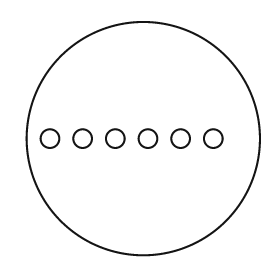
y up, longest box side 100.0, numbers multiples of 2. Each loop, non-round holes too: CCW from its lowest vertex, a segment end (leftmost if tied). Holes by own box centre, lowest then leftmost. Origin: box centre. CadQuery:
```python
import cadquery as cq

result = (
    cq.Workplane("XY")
    .moveTo(0.0, 0.0)
    .circle(50.0)
    .moveTo(-40.0, 0.0)
    .circle(4.0)
    .moveTo(-26.0, 0.0)
    .circle(4.0)
    .moveTo(-12.0, 0.0)
    .circle(4.0)
    .moveTo(2.0, 0.0)
    .circle(4.0)
    .moveTo(16.0, 0.0)
    .circle(4.0)
    .moveTo(30.0, 0.0)
    .circle(4.0)
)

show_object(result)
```